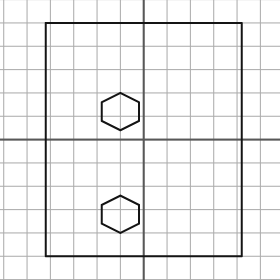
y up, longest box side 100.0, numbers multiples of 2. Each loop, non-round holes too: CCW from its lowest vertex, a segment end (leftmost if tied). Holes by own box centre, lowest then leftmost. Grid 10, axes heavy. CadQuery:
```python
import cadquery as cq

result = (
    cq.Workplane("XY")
    .moveTo(-42.0, -50.0)
    .lineTo(42.0, -50.0)
    .lineTo(42.0, 50.0)
    .lineTo(-42.0, 50.0)
    .close()
    .moveTo(-10.0, -40.0)
    .lineTo(-2.0, -36.0)
    .lineTo(-2.0, -28.0)
    .lineTo(-10.0, -24.0)
    .lineTo(-18.0, -28.0)
    .lineTo(-18.0, -36.0)
    .close()
    .moveTo(-10.0, 4.0)
    .lineTo(-2.0, 8.0)
    .lineTo(-2.0, 16.0)
    .lineTo(-10.0, 20.0)
    .lineTo(-18.0, 16.0)
    .lineTo(-18.0, 8.0)
    .close()
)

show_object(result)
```